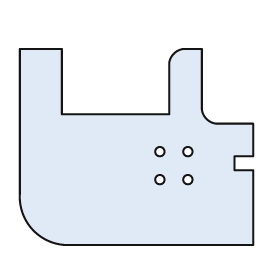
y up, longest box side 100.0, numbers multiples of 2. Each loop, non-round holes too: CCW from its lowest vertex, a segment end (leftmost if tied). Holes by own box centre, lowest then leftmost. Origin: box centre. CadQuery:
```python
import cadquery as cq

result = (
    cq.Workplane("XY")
    .moveTo(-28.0, -42.0)
    .lineTo(50.0, -42.0)
    .lineTo(50.0, -10.0)
    .lineTo(42.0, -10.0)
    .lineTo(42.0, -4.0)
    .lineTo(50.0, -4.0)
    .lineTo(50.0, 10.0)
    .lineTo(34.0, 10.0)
    .threePointArc((30.0, 12.0), (28.0, 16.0))
    .lineTo(28.0, 42.0)
    .lineTo(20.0, 42.0)
    .threePointArc((16.0, 40.0), (14.0, 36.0))
    .lineTo(14.0, 14.0)
    .lineTo(-32.0, 14.0)
    .lineTo(-32.0, 42.0)
    .lineTo(-50.0, 42.0)
    .lineTo(-50.0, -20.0)
    .threePointArc((-44.0, -36.0), (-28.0, -42.0))
    .close()
    .moveTo(10.0, -14.0)
    .circle(2.0)
    .moveTo(22.0, -14.0)
    .circle(2.0)
    .moveTo(10.0, -2.0)
    .circle(2.0)
    .moveTo(22.0, -2.0)
    .circle(2.0)
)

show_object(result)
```